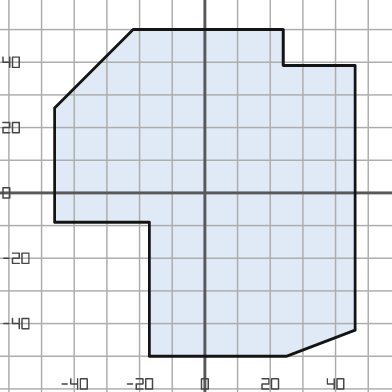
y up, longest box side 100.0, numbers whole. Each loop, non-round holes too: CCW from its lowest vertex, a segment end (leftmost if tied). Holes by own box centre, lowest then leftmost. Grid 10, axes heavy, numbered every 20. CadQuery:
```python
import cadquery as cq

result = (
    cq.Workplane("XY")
    .moveTo(-17.0, -50.0)
    .lineTo(25.0, -50.0)
    .lineTo(46.0, -42.0)
    .lineTo(46.0, 39.0)
    .lineTo(24.0, 39.0)
    .lineTo(24.0, 50.0)
    .lineTo(-22.0, 50.0)
    .lineTo(-46.0, 26.0)
    .lineTo(-46.0, -9.0)
    .lineTo(-17.0, -9.0)
    .close()
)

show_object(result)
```